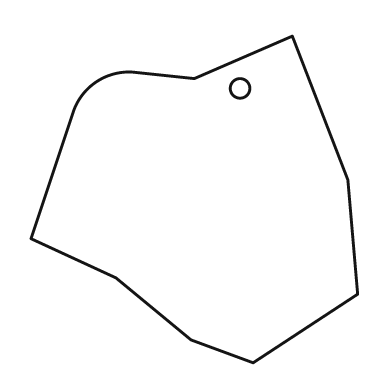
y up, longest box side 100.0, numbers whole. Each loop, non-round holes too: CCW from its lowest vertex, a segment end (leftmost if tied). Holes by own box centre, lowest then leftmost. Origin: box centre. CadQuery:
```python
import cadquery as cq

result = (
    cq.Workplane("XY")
    .moveTo(18.0, -50.0)
    .lineTo(50.0, -29.0)
    .lineTo(47.0, 6.0)
    .lineTo(30.0, 50.0)
    .lineTo(0.0, 37.0)
    .lineTo(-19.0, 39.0)
    .threePointArc((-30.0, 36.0), (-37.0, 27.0))
    .lineTo(-50.0, -12.0)
    .lineTo(-24.0, -24.0)
    .lineTo(-1.0, -43.0)
    .close()
    .moveTo(14.0, 34.0)
    .circle(3.0)
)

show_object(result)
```